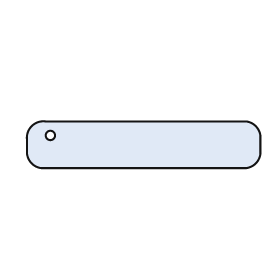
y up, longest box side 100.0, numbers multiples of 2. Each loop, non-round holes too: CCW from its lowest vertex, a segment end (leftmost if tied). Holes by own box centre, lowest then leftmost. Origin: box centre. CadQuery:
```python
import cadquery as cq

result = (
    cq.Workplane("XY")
    .moveTo(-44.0, -10.0)
    .lineTo(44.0, -10.0)
    .threePointArc((48.0, -8.0), (50.0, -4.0))
    .lineTo(50.0, 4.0)
    .threePointArc((48.0, 8.0), (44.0, 10.0))
    .lineTo(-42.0, 10.0)
    .threePointArc((-48.0, 8.0), (-50.0, 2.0))
    .lineTo(-50.0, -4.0)
    .threePointArc((-48.0, -8.0), (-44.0, -10.0))
    .close()
    .moveTo(-40.0, 4.0)
    .circle(2.0)
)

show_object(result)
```